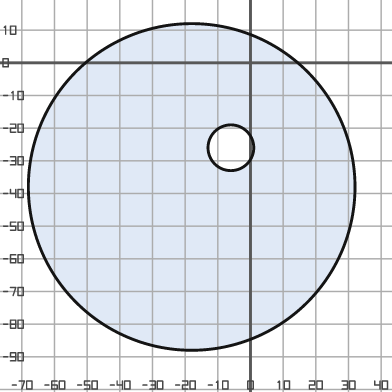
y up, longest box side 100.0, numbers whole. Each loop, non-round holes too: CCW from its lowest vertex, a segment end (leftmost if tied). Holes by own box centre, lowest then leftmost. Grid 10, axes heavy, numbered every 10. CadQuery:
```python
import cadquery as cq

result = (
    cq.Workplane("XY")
    .moveTo(-18.0, -38.0)
    .circle(50.0)
    .moveTo(-6.0, -26.0)
    .circle(7.0)
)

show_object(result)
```